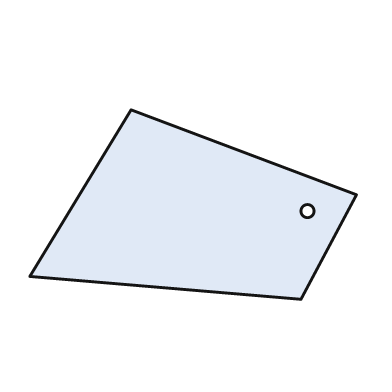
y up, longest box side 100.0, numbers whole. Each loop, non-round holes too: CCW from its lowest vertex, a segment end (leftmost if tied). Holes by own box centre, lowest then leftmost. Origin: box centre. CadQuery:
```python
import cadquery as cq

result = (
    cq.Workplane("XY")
    .moveTo(33.0, -29.0)
    .lineTo(50.0, 3.0)
    .lineTo(-19.0, 29.0)
    .lineTo(-50.0, -22.0)
    .close()
    .moveTo(35.0, -2.0)
    .circle(2.0)
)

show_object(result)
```